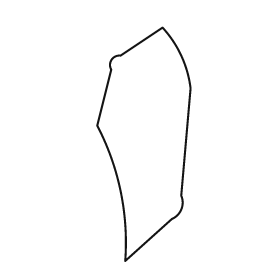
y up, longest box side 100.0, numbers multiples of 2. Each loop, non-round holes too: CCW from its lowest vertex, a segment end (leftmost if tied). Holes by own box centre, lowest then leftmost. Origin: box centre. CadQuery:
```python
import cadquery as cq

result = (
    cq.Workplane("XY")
    .moveTo(-8.0, -50.0)
    .lineTo(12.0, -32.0)
    .threePointArc((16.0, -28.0), (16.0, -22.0))
    .lineTo(20.0, 24.0)
    .threePointArc((16.0, 38.0), (8.0, 50.0))
    .lineTo(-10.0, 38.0)
    .threePointArc((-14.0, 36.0), (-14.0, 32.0))
    .lineTo(-20.0, 8.0)
    .threePointArc((-10.0, -20.0), (-8.0, -50.0))
    .close()
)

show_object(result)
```